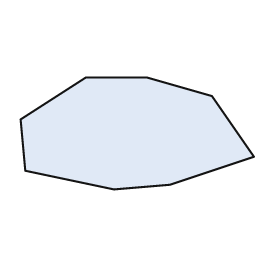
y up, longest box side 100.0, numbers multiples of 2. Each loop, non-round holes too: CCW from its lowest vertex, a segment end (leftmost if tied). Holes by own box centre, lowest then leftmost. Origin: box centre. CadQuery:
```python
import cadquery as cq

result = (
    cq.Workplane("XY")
    .moveTo(-10.0, -24.0)
    .lineTo(14.0, -22.0)
    .lineTo(50.0, -10.0)
    .lineTo(32.0, 16.0)
    .lineTo(4.0, 24.0)
    .lineTo(-22.0, 24.0)
    .lineTo(-50.0, 6.0)
    .lineTo(-48.0, -16.0)
    .close()
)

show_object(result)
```